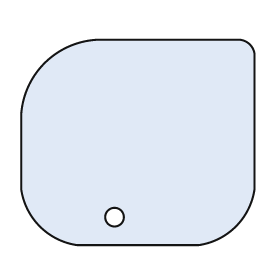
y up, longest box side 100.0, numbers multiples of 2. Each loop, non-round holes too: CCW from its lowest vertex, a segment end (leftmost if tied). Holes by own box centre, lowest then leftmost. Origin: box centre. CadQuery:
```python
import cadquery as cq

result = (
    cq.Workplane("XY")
    .moveTo(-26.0, -44.0)
    .lineTo(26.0, -44.0)
    .threePointArc((42.0, -36.0), (50.0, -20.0))
    .lineTo(50.0, 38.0)
    .threePointArc((48.0, 42.0), (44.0, 44.0))
    .lineTo(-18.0, 44.0)
    .threePointArc((-40.0, 34.0), (-50.0, 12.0))
    .lineTo(-50.0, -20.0)
    .threePointArc((-42.0, -36.0), (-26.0, -44.0))
    .close()
    .moveTo(-10.0, -32.0)
    .circle(4.0)
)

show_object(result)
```